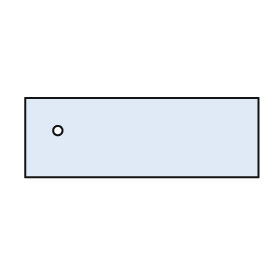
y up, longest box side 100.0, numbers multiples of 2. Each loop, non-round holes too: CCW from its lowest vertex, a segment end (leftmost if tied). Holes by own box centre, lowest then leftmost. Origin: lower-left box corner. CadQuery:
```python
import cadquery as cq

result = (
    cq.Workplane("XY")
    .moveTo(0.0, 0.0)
    .lineTo(100.0, 0.0)
    .lineTo(100.0, 34.0)
    .lineTo(0.0, 34.0)
    .close()
    .moveTo(14.0, 20.0)
    .circle(2.0)
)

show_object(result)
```